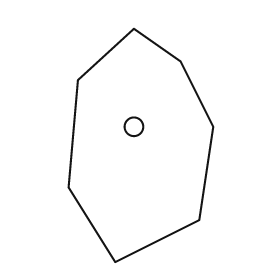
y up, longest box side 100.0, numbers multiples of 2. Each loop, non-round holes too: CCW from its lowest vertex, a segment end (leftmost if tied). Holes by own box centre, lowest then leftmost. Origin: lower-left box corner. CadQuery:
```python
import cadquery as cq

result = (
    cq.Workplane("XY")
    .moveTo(20.0, 0.0)
    .lineTo(56.0, 18.0)
    .lineTo(62.0, 58.0)
    .lineTo(48.0, 86.0)
    .lineTo(28.0, 100.0)
    .lineTo(4.0, 78.0)
    .lineTo(0.0, 32.0)
    .close()
    .moveTo(28.0, 58.0)
    .circle(4.0)
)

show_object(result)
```